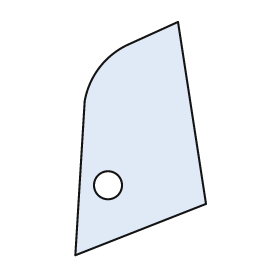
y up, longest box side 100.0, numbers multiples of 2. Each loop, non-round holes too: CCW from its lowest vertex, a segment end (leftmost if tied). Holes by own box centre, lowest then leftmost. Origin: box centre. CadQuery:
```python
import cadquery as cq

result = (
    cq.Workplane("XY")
    .moveTo(-28.0, -50.0)
    .lineTo(28.0, -28.0)
    .lineTo(16.0, 50.0)
    .lineTo(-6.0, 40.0)
    .threePointArc((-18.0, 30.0), (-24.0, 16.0))
    .close()
    .moveTo(-14.0, -20.0)
    .circle(6.0)
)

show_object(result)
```